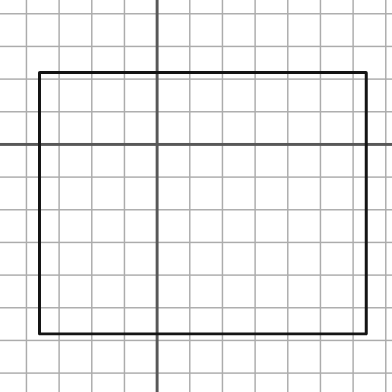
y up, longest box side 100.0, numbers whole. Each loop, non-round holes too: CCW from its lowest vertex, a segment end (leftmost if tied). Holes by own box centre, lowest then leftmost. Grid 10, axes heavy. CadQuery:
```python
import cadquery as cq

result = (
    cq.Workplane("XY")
    .moveTo(-36.0, -58.0)
    .lineTo(64.0, -58.0)
    .lineTo(64.0, 22.0)
    .lineTo(-36.0, 22.0)
    .close()
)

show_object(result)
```